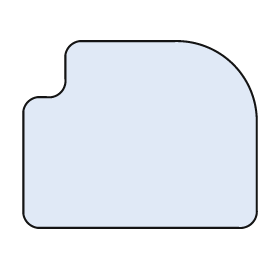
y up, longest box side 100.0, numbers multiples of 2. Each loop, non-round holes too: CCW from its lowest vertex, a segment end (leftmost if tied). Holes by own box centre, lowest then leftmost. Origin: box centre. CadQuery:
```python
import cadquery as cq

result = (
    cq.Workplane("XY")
    .moveTo(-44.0, -40.0)
    .lineTo(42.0, -40.0)
    .threePointArc((48.0, -38.0), (50.0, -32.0))
    .lineTo(50.0, 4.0)
    .threePointArc((40.0, 30.0), (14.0, 40.0))
    .lineTo(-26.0, 40.0)
    .threePointArc((-30.0, 38.0), (-32.0, 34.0))
    .lineTo(-32.0, 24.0)
    .threePointArc((-34.0, 18.0), (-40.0, 16.0))
    .lineTo(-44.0, 16.0)
    .threePointArc((-48.0, 14.0), (-50.0, 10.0))
    .lineTo(-50.0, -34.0)
    .threePointArc((-48.0, -38.0), (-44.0, -40.0))
    .close()
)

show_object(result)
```